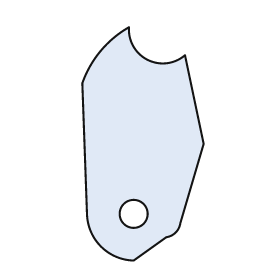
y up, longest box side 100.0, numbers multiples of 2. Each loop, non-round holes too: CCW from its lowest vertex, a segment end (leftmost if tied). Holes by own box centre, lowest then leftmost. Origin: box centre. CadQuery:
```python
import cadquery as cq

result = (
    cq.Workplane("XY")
    .moveTo(-4.0, -50.0)
    .lineTo(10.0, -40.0)
    .threePointArc((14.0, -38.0), (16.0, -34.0))
    .lineTo(26.0, 0.0)
    .lineTo(18.0, 38.0)
    .threePointArc((2.0, 36.0), (-6.0, 50.0))
    .threePointArc((-18.0, 40.0), (-26.0, 26.0))
    .lineTo(-24.0, -30.0)
    .threePointArc((-18.0, -44.0), (-4.0, -50.0))
    .close()
    .moveTo(-4.0, -30.0)
    .circle(6.0)
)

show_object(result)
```